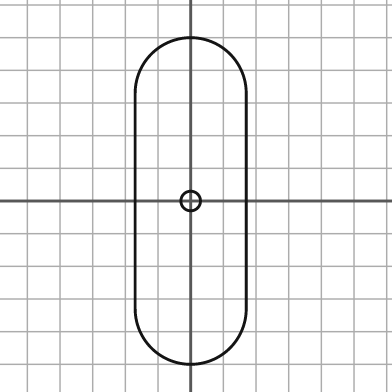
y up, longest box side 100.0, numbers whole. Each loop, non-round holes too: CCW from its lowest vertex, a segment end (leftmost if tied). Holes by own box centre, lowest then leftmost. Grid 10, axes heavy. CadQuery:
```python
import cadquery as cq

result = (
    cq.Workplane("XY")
    .moveTo(-17.0, -33.0)
    .threePointArc((0.0, -50.0), (17.0, -33.0))
    .lineTo(17.0, 33.0)
    .threePointArc((0.0, 50.0), (-17.0, 33.0))
    .close()
    .moveTo(0.0, 0.0)
    .circle(3.0)
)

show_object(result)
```